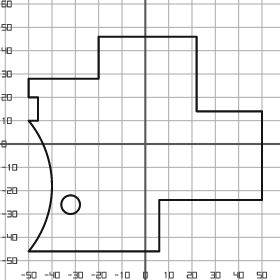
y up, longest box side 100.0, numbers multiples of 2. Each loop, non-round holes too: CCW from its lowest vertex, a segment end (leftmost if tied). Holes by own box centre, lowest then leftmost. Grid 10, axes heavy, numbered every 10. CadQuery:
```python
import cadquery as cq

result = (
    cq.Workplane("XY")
    .moveTo(-50.0, -46.0)
    .lineTo(6.0, -46.0)
    .lineTo(6.0, -24.0)
    .lineTo(50.0, -24.0)
    .lineTo(50.0, 14.0)
    .lineTo(22.0, 14.0)
    .lineTo(22.0, 46.0)
    .lineTo(-20.0, 46.0)
    .lineTo(-20.0, 28.0)
    .lineTo(-50.0, 28.0)
    .lineTo(-50.0, 20.0)
    .lineTo(-46.0, 20.0)
    .lineTo(-46.0, 10.0)
    .lineTo(-50.0, 10.0)
    .threePointArc((-40.0, -18.0), (-50.0, -46.0))
    .close()
    .moveTo(-32.0, -26.0)
    .circle(4.0)
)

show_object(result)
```